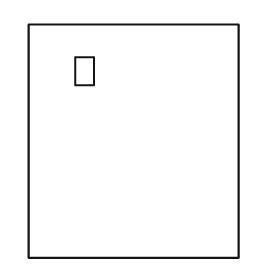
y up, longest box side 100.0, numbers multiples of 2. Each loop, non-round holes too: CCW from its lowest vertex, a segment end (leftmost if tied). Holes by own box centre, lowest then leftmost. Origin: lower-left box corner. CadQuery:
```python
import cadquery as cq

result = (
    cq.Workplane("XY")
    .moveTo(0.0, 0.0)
    .lineTo(90.0, 0.0)
    .lineTo(90.0, 100.0)
    .lineTo(0.0, 100.0)
    .close()
    .moveTo(20.0, 74.0)
    .lineTo(28.0, 74.0)
    .lineTo(28.0, 86.0)
    .lineTo(20.0, 86.0)
    .close()
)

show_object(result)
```